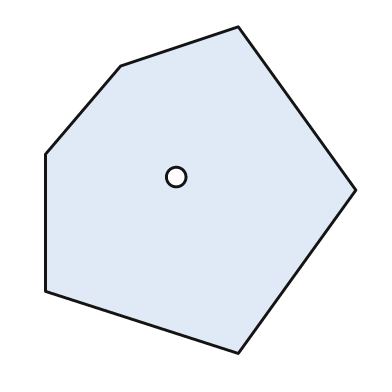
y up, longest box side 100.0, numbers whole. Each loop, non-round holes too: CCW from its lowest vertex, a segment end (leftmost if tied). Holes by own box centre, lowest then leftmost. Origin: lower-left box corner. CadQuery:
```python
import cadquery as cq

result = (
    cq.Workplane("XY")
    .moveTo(59.0, 0.0)
    .lineTo(95.0, 50.0)
    .lineTo(59.0, 100.0)
    .lineTo(23.0, 88.0)
    .lineTo(0.0, 61.0)
    .lineTo(0.0, 19.0)
    .close()
    .moveTo(40.0, 54.0)
    .circle(3.0)
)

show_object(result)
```